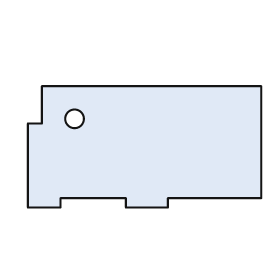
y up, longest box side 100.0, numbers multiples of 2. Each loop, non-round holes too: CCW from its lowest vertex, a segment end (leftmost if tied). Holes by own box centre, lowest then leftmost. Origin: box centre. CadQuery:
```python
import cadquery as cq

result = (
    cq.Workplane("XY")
    .moveTo(-50.0, -26.0)
    .lineTo(-36.0, -26.0)
    .lineTo(-36.0, -22.0)
    .lineTo(-8.0, -22.0)
    .lineTo(-8.0, -26.0)
    .lineTo(10.0, -26.0)
    .lineTo(10.0, -22.0)
    .lineTo(50.0, -22.0)
    .lineTo(50.0, 26.0)
    .lineTo(-44.0, 26.0)
    .lineTo(-44.0, 10.0)
    .lineTo(-50.0, 10.0)
    .close()
    .moveTo(-30.0, 12.0)
    .circle(4.0)
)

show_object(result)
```